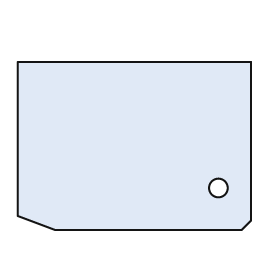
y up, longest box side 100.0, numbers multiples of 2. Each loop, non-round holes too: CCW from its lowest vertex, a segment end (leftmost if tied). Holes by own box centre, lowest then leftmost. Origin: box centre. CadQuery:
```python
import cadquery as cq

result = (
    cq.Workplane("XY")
    .moveTo(-34.0, -36.0)
    .lineTo(46.0, -36.0)
    .lineTo(50.0, -32.0)
    .lineTo(50.0, 36.0)
    .lineTo(-50.0, 36.0)
    .lineTo(-50.0, -30.0)
    .close()
    .moveTo(36.0, -18.0)
    .circle(4.0)
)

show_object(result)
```